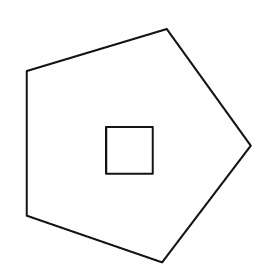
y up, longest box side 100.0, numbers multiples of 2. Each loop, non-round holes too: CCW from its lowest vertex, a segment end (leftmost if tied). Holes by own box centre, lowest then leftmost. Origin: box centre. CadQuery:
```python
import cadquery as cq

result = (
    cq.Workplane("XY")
    .moveTo(10.0, -50.0)
    .lineTo(48.0, 0.0)
    .lineTo(12.0, 50.0)
    .lineTo(-48.0, 32.0)
    .lineTo(-48.0, -30.0)
    .close()
    .moveTo(-14.0, -12.0)
    .lineTo(6.0, -12.0)
    .lineTo(6.0, 8.0)
    .lineTo(-14.0, 8.0)
    .close()
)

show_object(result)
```